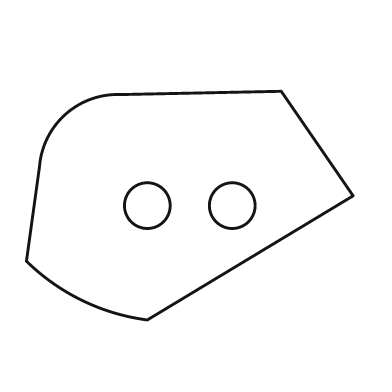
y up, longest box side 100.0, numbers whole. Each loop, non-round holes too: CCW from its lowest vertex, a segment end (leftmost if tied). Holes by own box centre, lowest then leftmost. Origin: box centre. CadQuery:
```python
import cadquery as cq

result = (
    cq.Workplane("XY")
    .moveTo(-13.0, -35.0)
    .lineTo(50.0, 3.0)
    .lineTo(28.0, 35.0)
    .lineTo(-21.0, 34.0)
    .threePointArc((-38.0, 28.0), (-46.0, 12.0))
    .lineTo(-50.0, -17.0)
    .threePointArc((-33.0, -29.0), (-13.0, -35.0))
    .close()
    .moveTo(-13.0, 0.0)
    .circle(7.0)
    .moveTo(13.0, 0.0)
    .circle(7.0)
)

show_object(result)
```